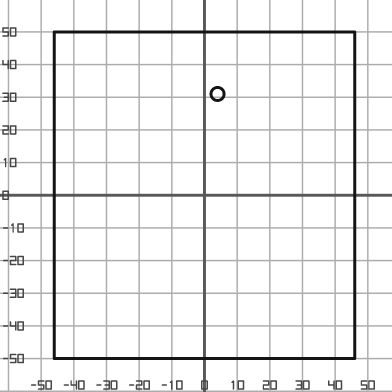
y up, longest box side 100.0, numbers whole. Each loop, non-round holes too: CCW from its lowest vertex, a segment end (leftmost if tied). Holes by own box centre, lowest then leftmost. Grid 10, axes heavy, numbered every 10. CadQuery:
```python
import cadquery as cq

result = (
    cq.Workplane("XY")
    .moveTo(-46.0, -50.0)
    .lineTo(46.0, -50.0)
    .lineTo(46.0, 50.0)
    .lineTo(-46.0, 50.0)
    .close()
    .moveTo(4.0, 31.0)
    .circle(2.0)
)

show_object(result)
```